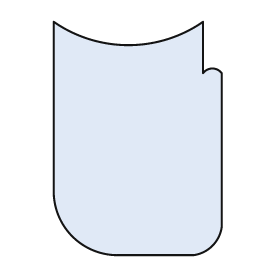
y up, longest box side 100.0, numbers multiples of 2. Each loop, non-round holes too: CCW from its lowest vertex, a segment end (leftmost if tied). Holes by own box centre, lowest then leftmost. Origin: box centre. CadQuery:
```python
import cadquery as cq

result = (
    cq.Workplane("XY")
    .moveTo(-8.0, -50.0)
    .lineTo(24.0, -50.0)
    .threePointArc((32.0, -46.0), (36.0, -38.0))
    .lineTo(36.0, 28.0)
    .threePointArc((32.0, 30.0), (28.0, 28.0))
    .lineTo(28.0, 50.0)
    .threePointArc((-4.0, 40.0), (-36.0, 50.0))
    .lineTo(-36.0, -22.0)
    .threePointArc((-28.0, -42.0), (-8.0, -50.0))
    .close()
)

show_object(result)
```